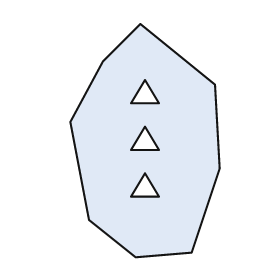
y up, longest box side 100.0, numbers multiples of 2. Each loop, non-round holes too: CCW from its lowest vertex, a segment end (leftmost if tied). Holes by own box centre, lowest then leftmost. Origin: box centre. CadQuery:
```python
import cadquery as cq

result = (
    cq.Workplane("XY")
    .moveTo(-4.0, -50.0)
    .lineTo(20.0, -48.0)
    .lineTo(32.0, -12.0)
    .lineTo(30.0, 24.0)
    .lineTo(-2.0, 50.0)
    .lineTo(-18.0, 34.0)
    .lineTo(-32.0, 8.0)
    .lineTo(-24.0, -34.0)
    .close()
    .moveTo(-6.0, -24.0)
    .lineTo(6.0, -24.0)
    .lineTo(0.0, -14.0)
    .close()
    .moveTo(-6.0, -4.0)
    .lineTo(6.0, -4.0)
    .lineTo(0.0, 6.0)
    .close()
    .moveTo(-6.0, 16.0)
    .lineTo(6.0, 16.0)
    .lineTo(0.0, 26.0)
    .close()
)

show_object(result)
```